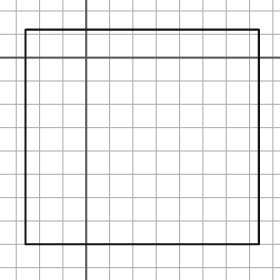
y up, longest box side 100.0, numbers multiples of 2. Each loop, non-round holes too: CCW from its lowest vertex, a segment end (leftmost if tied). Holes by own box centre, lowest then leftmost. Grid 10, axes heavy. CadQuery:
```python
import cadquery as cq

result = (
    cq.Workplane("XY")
    .moveTo(-26.0, -80.0)
    .lineTo(74.0, -80.0)
    .lineTo(74.0, 12.0)
    .lineTo(-26.0, 12.0)
    .close()
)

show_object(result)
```